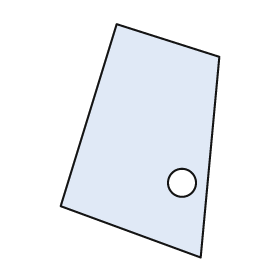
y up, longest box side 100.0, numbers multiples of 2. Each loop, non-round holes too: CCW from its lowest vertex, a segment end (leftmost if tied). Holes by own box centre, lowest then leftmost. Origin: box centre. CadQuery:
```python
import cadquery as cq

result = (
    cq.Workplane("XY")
    .moveTo(26.0, -50.0)
    .lineTo(34.0, 36.0)
    .lineTo(-10.0, 50.0)
    .lineTo(-34.0, -28.0)
    .close()
    .moveTo(18.0, -18.0)
    .circle(6.0)
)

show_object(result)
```